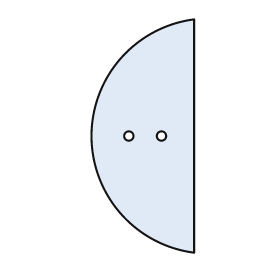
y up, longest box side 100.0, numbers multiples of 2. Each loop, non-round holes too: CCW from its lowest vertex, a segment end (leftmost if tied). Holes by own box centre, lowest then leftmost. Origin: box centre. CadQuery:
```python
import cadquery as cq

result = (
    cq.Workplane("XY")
    .moveTo(22.0, -50.0)
    .lineTo(22.0, 50.0)
    .threePointArc((-22.0, 0.0), (22.0, -50.0))
    .close()
    .moveTo(-6.0, 0.0)
    .circle(2.0)
    .moveTo(8.0, 0.0)
    .circle(2.0)
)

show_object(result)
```